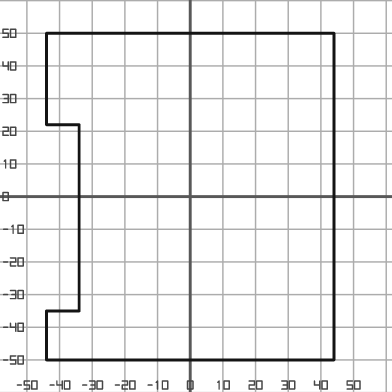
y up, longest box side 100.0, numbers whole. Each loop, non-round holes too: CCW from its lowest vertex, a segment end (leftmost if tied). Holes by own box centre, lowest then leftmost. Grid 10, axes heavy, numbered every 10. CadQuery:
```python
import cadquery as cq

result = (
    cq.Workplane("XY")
    .moveTo(-44.0, -50.0)
    .lineTo(44.0, -50.0)
    .lineTo(44.0, 50.0)
    .lineTo(-44.0, 50.0)
    .lineTo(-44.0, 22.0)
    .lineTo(-34.0, 22.0)
    .lineTo(-34.0, -35.0)
    .lineTo(-44.0, -35.0)
    .close()
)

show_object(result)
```